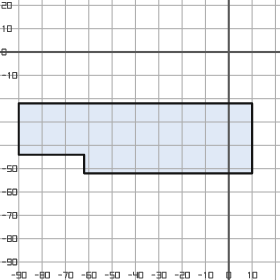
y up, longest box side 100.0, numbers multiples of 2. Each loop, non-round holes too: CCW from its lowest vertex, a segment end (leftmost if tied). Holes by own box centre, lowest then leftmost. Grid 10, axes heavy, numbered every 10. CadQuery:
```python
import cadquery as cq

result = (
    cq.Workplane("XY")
    .moveTo(-62.0, -52.0)
    .lineTo(10.0, -52.0)
    .lineTo(10.0, -22.0)
    .lineTo(-90.0, -22.0)
    .lineTo(-90.0, -44.0)
    .lineTo(-62.0, -44.0)
    .close()
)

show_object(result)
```